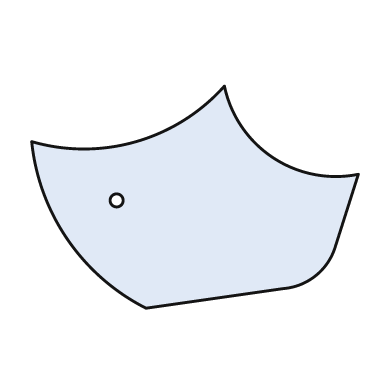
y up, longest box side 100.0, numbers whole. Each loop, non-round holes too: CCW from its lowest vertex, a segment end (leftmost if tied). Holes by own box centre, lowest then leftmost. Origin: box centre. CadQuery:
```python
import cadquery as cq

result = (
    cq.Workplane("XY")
    .moveTo(-15.0, -34.0)
    .lineTo(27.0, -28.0)
    .threePointArc((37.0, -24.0), (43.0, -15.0))
    .lineTo(50.0, 7.0)
    .threePointArc((24.0, 12.0), (9.0, 34.0))
    .threePointArc((-18.0, 17.0), (-50.0, 17.0))
    .threePointArc((-39.0, -13.0), (-15.0, -34.0))
    .close()
    .moveTo(-24.0, -1.0)
    .circle(2.0)
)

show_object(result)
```